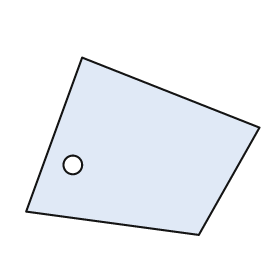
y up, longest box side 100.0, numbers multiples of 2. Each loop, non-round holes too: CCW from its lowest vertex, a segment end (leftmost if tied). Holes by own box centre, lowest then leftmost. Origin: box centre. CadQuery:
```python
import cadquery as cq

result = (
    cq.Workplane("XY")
    .moveTo(24.0, -38.0)
    .lineTo(50.0, 8.0)
    .lineTo(-26.0, 38.0)
    .lineTo(-50.0, -28.0)
    .close()
    .moveTo(-30.0, -8.0)
    .circle(4.0)
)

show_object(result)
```